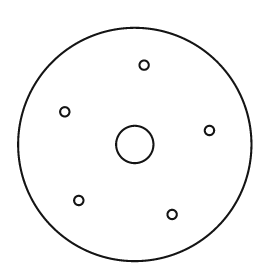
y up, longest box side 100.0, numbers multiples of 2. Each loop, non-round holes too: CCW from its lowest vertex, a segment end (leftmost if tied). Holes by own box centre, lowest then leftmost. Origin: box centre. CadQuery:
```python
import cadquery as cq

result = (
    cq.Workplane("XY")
    .moveTo(0.0, 0.0)
    .circle(50.0)
    .moveTo(16.0, -30.0)
    .circle(2.0)
    .moveTo(-24.0, -24.0)
    .circle(2.0)
    .moveTo(0.0, 0.0)
    .circle(8.0)
    .moveTo(32.0, 6.0)
    .circle(2.0)
    .moveTo(-30.0, 14.0)
    .circle(2.0)
    .moveTo(4.0, 34.0)
    .circle(2.0)
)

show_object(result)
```